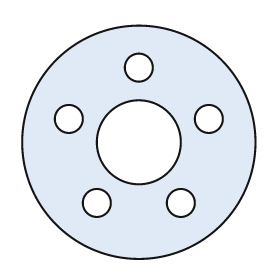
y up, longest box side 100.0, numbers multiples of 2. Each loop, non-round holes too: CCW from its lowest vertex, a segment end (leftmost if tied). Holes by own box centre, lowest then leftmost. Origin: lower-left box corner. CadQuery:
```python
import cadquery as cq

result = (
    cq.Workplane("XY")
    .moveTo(50.0, 50.0)
    .circle(50.0)
    .moveTo(32.0, 24.0)
    .circle(6.0)
    .moveTo(68.0, 24.0)
    .circle(6.0)
    .moveTo(50.0, 50.0)
    .circle(18.0)
    .moveTo(20.0, 60.0)
    .circle(6.0)
    .moveTo(80.0, 60.0)
    .circle(6.0)
    .moveTo(50.0, 82.0)
    .circle(6.0)
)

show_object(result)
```